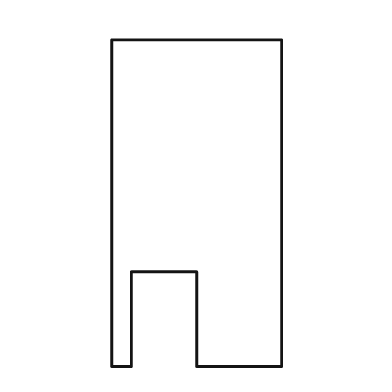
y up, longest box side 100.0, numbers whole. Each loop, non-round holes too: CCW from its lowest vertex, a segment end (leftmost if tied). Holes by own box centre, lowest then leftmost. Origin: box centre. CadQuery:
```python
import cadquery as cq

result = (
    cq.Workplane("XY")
    .moveTo(-26.0, -50.0)
    .lineTo(-20.0, -50.0)
    .lineTo(-20.0, -21.0)
    .lineTo(0.0, -21.0)
    .lineTo(0.0, -50.0)
    .lineTo(26.0, -50.0)
    .lineTo(26.0, 50.0)
    .lineTo(-26.0, 50.0)
    .close()
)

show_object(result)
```